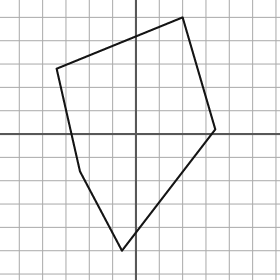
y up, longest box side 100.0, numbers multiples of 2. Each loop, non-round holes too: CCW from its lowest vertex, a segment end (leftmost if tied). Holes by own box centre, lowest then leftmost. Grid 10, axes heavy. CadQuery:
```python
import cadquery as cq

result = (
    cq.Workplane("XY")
    .moveTo(-6.0, -50.0)
    .lineTo(34.0, 2.0)
    .lineTo(20.0, 50.0)
    .lineTo(-34.0, 28.0)
    .lineTo(-24.0, -16.0)
    .close()
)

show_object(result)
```